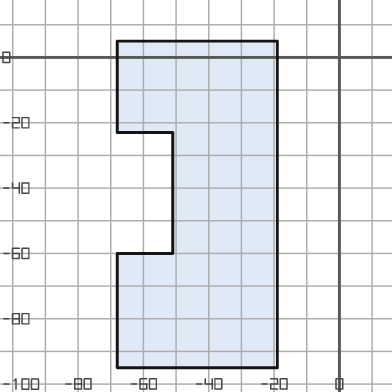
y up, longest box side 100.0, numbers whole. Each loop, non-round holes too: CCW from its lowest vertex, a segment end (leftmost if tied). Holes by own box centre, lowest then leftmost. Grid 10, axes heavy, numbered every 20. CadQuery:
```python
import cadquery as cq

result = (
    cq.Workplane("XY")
    .moveTo(-68.0, -95.0)
    .lineTo(-19.0, -95.0)
    .lineTo(-19.0, 5.0)
    .lineTo(-68.0, 5.0)
    .lineTo(-68.0, -23.0)
    .lineTo(-51.0, -23.0)
    .lineTo(-51.0, -60.0)
    .lineTo(-68.0, -60.0)
    .close()
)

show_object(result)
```